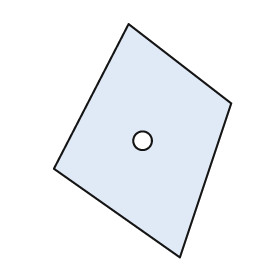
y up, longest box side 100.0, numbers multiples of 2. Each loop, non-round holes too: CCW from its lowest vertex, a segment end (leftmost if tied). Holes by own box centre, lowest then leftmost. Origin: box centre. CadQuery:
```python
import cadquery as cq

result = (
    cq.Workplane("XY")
    .moveTo(16.0, -50.0)
    .lineTo(38.0, 16.0)
    .lineTo(-6.0, 50.0)
    .lineTo(-38.0, -12.0)
    .close()
    .moveTo(0.0, 0.0)
    .circle(4.0)
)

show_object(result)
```